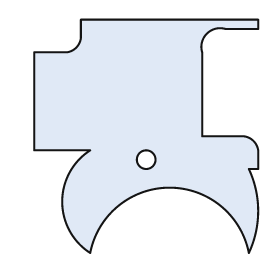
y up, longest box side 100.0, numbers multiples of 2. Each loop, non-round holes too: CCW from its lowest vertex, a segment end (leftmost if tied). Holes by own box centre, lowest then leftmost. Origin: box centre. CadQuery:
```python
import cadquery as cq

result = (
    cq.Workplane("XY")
    .moveTo(-24.0, -50.0)
    .threePointArc((10.0, -22.0), (44.0, -50.0))
    .threePointArc((48.0, -32.0), (44.0, -14.0))
    .lineTo(48.0, -14.0)
    .lineTo(48.0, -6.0)
    .threePointArc((46.0, -2.0), (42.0, 0.0))
    .lineTo(24.0, 0.0)
    .lineTo(24.0, 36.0)
    .threePointArc((26.0, 44.0), (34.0, 46.0))
    .lineTo(48.0, 46.0)
    .lineTo(48.0, 50.0)
    .lineTo(-28.0, 50.0)
    .lineTo(-28.0, 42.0)
    .threePointArc((-30.0, 38.0), (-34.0, 36.0))
    .lineTo(-48.0, 36.0)
    .lineTo(-48.0, -6.0)
    .lineTo(-24.0, -6.0)
    .threePointArc((-36.0, -28.0), (-24.0, -50.0))
    .close()
    .moveTo(0.0, -10.0)
    .circle(4.0)
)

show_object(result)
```